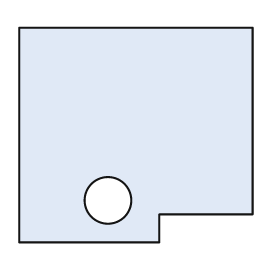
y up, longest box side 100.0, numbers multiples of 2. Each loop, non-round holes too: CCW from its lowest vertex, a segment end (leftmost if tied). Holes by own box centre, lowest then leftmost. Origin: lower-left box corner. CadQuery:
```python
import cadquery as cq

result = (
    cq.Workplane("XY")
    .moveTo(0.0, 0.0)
    .lineTo(60.0, 0.0)
    .lineTo(60.0, 12.0)
    .lineTo(100.0, 12.0)
    .lineTo(100.0, 92.0)
    .lineTo(0.0, 92.0)
    .close()
    .moveTo(38.0, 18.0)
    .circle(10.0)
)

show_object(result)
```